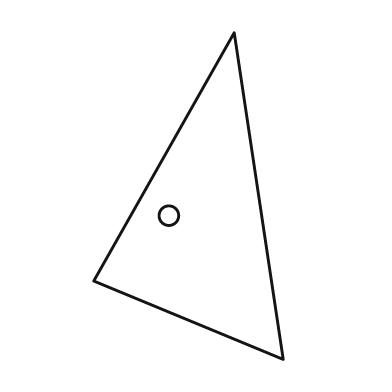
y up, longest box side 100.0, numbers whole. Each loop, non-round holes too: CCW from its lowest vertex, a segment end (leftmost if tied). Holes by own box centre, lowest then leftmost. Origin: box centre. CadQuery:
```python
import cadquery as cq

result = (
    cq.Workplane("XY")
    .moveTo(29.0, -50.0)
    .lineTo(14.0, 50.0)
    .lineTo(-29.0, -26.0)
    .close()
    .moveTo(-6.0, -6.0)
    .circle(3.0)
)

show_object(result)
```